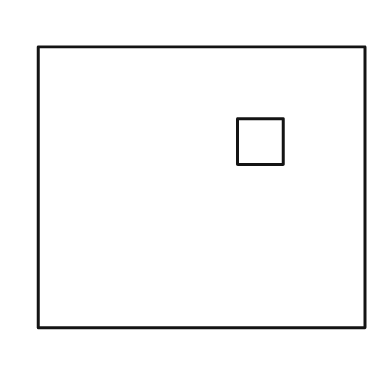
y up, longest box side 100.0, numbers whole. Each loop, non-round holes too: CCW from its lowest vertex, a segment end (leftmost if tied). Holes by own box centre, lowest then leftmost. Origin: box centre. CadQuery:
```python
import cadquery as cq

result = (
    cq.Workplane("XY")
    .moveTo(-50.0, -43.0)
    .lineTo(50.0, -43.0)
    .lineTo(50.0, 43.0)
    .lineTo(-50.0, 43.0)
    .close()
    .moveTo(11.0, 7.0)
    .lineTo(25.0, 7.0)
    .lineTo(25.0, 21.0)
    .lineTo(11.0, 21.0)
    .close()
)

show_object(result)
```